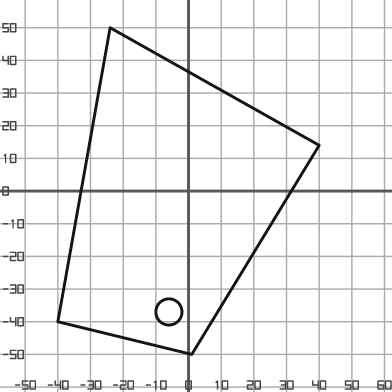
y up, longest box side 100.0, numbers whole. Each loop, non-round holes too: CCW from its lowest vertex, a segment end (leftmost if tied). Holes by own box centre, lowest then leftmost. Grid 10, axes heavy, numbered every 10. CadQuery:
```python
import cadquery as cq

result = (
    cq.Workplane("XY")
    .moveTo(1.0, -50.0)
    .lineTo(40.0, 14.0)
    .lineTo(-24.0, 50.0)
    .lineTo(-40.0, -40.0)
    .close()
    .moveTo(-6.0, -37.0)
    .circle(4.0)
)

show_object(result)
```